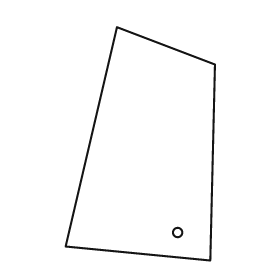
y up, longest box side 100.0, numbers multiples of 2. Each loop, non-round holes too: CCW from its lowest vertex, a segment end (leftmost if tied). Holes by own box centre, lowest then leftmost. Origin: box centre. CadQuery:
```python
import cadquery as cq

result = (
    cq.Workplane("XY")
    .moveTo(30.0, -50.0)
    .lineTo(32.0, 34.0)
    .lineTo(-10.0, 50.0)
    .lineTo(-32.0, -44.0)
    .close()
    .moveTo(16.0, -38.0)
    .circle(2.0)
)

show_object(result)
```